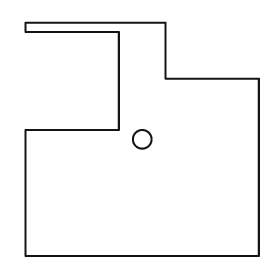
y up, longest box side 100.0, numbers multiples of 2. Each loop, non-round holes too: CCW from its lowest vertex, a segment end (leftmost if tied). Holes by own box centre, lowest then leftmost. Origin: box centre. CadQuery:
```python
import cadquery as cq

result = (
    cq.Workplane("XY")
    .moveTo(-50.0, -50.0)
    .lineTo(50.0, -50.0)
    .lineTo(50.0, 26.0)
    .lineTo(10.0, 26.0)
    .lineTo(10.0, 50.0)
    .lineTo(-50.0, 50.0)
    .lineTo(-50.0, 46.0)
    .lineTo(-10.0, 46.0)
    .lineTo(-10.0, 4.0)
    .lineTo(-50.0, 4.0)
    .close()
    .moveTo(0.0, 0.0)
    .circle(4.0)
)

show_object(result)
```